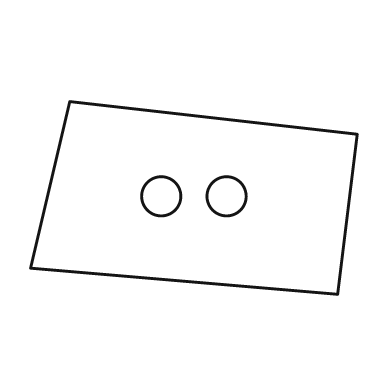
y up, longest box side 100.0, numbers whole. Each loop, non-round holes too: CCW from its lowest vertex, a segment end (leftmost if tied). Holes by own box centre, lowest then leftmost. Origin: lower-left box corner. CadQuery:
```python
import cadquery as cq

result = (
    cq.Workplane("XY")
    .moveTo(94.0, 0.0)
    .lineTo(100.0, 49.0)
    .lineTo(12.0, 59.0)
    .lineTo(0.0, 8.0)
    .close()
    .moveTo(40.0, 30.0)
    .circle(6.0)
    .moveTo(60.0, 30.0)
    .circle(6.0)
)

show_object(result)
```